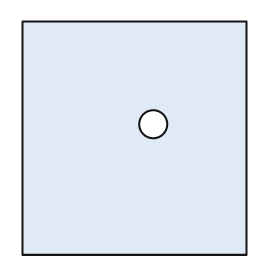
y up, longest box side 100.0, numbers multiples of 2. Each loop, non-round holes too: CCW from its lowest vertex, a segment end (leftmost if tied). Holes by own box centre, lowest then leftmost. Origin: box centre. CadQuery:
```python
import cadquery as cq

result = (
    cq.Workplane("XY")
    .moveTo(-48.0, -50.0)
    .lineTo(48.0, -50.0)
    .lineTo(48.0, 50.0)
    .lineTo(-48.0, 50.0)
    .close()
    .moveTo(8.0, 6.0)
    .circle(6.0)
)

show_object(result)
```